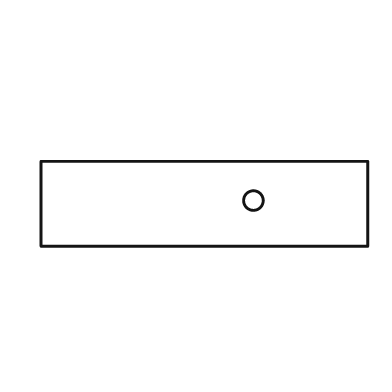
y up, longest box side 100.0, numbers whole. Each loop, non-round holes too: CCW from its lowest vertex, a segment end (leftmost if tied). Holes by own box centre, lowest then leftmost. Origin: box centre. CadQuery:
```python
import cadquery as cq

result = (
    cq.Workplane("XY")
    .moveTo(-50.0, -13.0)
    .lineTo(50.0, -13.0)
    .lineTo(50.0, 13.0)
    .lineTo(-50.0, 13.0)
    .close()
    .moveTo(15.0, 1.0)
    .circle(3.0)
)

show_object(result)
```